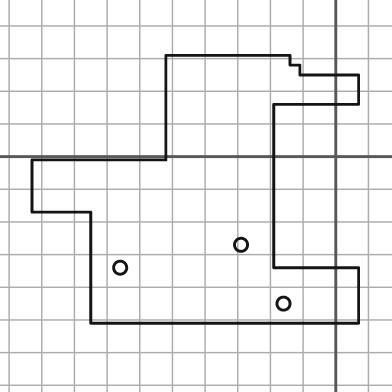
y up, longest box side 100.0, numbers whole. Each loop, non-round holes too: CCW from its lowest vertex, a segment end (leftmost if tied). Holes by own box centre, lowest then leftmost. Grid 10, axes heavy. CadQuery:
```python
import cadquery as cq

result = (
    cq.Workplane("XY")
    .moveTo(-75.0, -51.0)
    .lineTo(7.0, -51.0)
    .lineTo(7.0, -34.0)
    .lineTo(-19.0, -34.0)
    .lineTo(-19.0, 16.0)
    .lineTo(7.0, 16.0)
    .lineTo(7.0, 25.0)
    .lineTo(-11.0, 25.0)
    .lineTo(-11.0, 28.0)
    .lineTo(-14.0, 28.0)
    .lineTo(-14.0, 31.0)
    .lineTo(-52.0, 31.0)
    .lineTo(-52.0, -1.0)
    .lineTo(-93.0, -1.0)
    .lineTo(-93.0, -17.0)
    .lineTo(-75.0, -17.0)
    .close()
    .moveTo(-16.0, -45.0)
    .circle(2.0)
    .moveTo(-66.0, -34.0)
    .circle(2.0)
    .moveTo(-29.0, -27.0)
    .circle(2.0)
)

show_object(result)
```